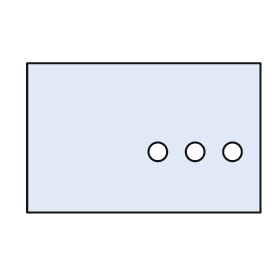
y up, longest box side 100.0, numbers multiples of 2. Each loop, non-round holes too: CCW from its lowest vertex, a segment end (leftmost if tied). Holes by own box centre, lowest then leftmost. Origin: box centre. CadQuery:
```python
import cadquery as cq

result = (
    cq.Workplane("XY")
    .moveTo(-50.0, -32.0)
    .lineTo(50.0, -32.0)
    .lineTo(50.0, 32.0)
    .lineTo(-50.0, 32.0)
    .close()
    .moveTo(6.0, -6.0)
    .circle(4.0)
    .moveTo(22.0, -6.0)
    .circle(4.0)
    .moveTo(38.0, -6.0)
    .circle(4.0)
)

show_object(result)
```